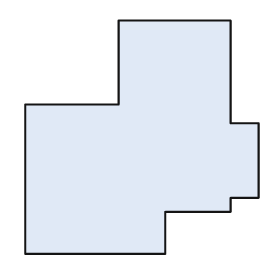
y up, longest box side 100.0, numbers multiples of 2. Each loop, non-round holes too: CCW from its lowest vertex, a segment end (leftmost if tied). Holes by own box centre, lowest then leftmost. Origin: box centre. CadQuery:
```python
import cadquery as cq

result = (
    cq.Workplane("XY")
    .moveTo(-50.0, -50.0)
    .lineTo(10.0, -50.0)
    .lineTo(10.0, -32.0)
    .lineTo(38.0, -32.0)
    .lineTo(38.0, -26.0)
    .lineTo(50.0, -26.0)
    .lineTo(50.0, 6.0)
    .lineTo(38.0, 6.0)
    .lineTo(38.0, 50.0)
    .lineTo(-10.0, 50.0)
    .lineTo(-10.0, 14.0)
    .lineTo(-50.0, 14.0)
    .close()
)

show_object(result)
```